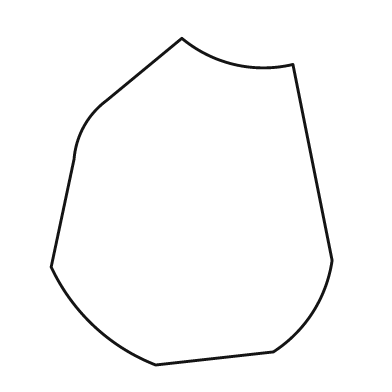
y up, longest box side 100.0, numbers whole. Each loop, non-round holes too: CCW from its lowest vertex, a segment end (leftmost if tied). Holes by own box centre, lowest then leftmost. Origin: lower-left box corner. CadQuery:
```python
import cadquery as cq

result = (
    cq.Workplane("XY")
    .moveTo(32.0, 0.0)
    .lineTo(68.0, 4.0)
    .threePointArc((80.0, 16.0), (86.0, 32.0))
    .lineTo(74.0, 92.0)
    .threePointArc((56.0, 92.0), (40.0, 100.0))
    .lineTo(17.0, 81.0)
    .threePointArc((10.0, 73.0), (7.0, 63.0))
    .lineTo(0.0, 30.0)
    .threePointArc((13.0, 12.0), (32.0, 0.0))
    .close()
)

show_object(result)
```